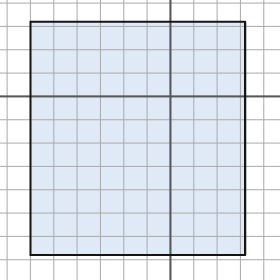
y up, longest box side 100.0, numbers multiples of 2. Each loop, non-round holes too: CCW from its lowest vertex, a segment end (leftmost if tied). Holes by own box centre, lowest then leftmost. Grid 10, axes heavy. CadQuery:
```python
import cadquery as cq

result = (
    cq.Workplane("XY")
    .moveTo(-60.0, -68.0)
    .lineTo(32.0, -68.0)
    .lineTo(32.0, 32.0)
    .lineTo(-60.0, 32.0)
    .close()
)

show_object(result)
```